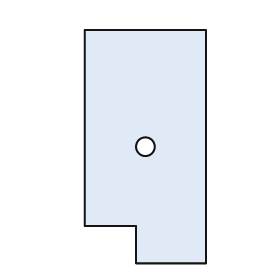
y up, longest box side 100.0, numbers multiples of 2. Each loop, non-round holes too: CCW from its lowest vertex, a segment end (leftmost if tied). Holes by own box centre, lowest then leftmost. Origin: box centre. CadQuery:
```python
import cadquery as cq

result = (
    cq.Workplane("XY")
    .moveTo(-4.0, -50.0)
    .lineTo(26.0, -50.0)
    .lineTo(26.0, 50.0)
    .lineTo(-26.0, 50.0)
    .lineTo(-26.0, -34.0)
    .lineTo(-4.0, -34.0)
    .close()
    .moveTo(0.0, 0.0)
    .circle(4.0)
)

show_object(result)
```